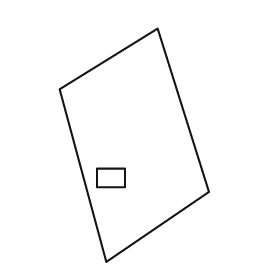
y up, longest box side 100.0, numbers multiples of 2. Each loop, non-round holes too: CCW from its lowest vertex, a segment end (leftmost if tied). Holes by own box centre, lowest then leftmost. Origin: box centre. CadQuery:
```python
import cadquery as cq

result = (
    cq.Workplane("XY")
    .moveTo(-12.0, -50.0)
    .lineTo(32.0, -20.0)
    .lineTo(10.0, 50.0)
    .lineTo(-32.0, 24.0)
    .close()
    .moveTo(-16.0, -18.0)
    .lineTo(-4.0, -18.0)
    .lineTo(-4.0, -10.0)
    .lineTo(-16.0, -10.0)
    .close()
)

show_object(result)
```